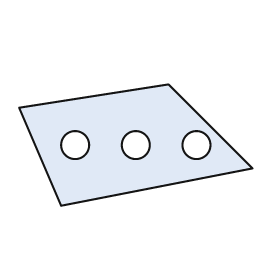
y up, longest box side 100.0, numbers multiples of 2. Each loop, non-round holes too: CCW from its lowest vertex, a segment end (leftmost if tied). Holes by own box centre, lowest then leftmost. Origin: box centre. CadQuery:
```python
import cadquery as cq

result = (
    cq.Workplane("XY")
    .moveTo(-32.0, -26.0)
    .lineTo(50.0, -10.0)
    .lineTo(14.0, 26.0)
    .lineTo(-50.0, 16.0)
    .close()
    .moveTo(-26.0, 0.0)
    .circle(6.0)
    .moveTo(0.0, 0.0)
    .circle(6.0)
    .moveTo(26.0, 0.0)
    .circle(6.0)
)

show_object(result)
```